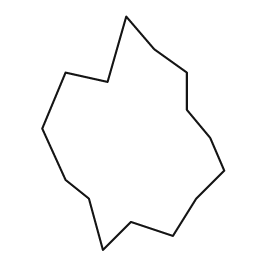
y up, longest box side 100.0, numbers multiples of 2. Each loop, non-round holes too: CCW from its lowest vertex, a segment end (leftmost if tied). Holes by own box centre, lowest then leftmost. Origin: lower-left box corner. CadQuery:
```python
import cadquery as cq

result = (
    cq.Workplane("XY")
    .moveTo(26.0, 0.0)
    .lineTo(38.0, 12.0)
    .lineTo(56.0, 6.0)
    .lineTo(66.0, 22.0)
    .lineTo(78.0, 34.0)
    .lineTo(72.0, 48.0)
    .lineTo(62.0, 60.0)
    .lineTo(62.0, 76.0)
    .lineTo(48.0, 86.0)
    .lineTo(36.0, 100.0)
    .lineTo(28.0, 72.0)
    .lineTo(10.0, 76.0)
    .lineTo(0.0, 52.0)
    .lineTo(10.0, 30.0)
    .lineTo(20.0, 22.0)
    .close()
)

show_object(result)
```